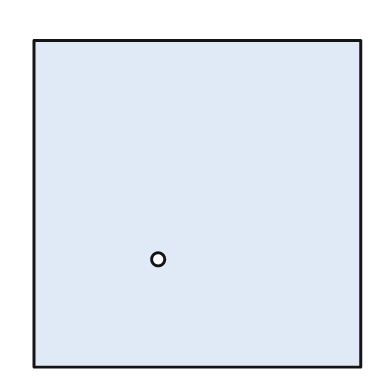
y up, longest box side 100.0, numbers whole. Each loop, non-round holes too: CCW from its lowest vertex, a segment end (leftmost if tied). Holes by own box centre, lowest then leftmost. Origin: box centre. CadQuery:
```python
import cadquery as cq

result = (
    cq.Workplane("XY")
    .moveTo(-50.0, -50.0)
    .lineTo(50.0, -50.0)
    .lineTo(50.0, 50.0)
    .lineTo(-50.0, 50.0)
    .close()
    .moveTo(-12.0, -17.0)
    .circle(2.0)
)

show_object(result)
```